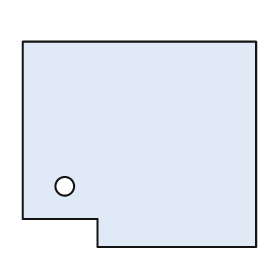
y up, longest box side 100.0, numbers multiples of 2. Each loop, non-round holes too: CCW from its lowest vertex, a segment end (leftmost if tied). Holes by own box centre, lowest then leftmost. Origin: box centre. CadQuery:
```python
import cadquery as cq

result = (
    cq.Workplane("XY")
    .moveTo(-18.0, -44.0)
    .lineTo(50.0, -44.0)
    .lineTo(50.0, 44.0)
    .lineTo(-50.0, 44.0)
    .lineTo(-50.0, -32.0)
    .lineTo(-18.0, -32.0)
    .close()
    .moveTo(-32.0, -18.0)
    .circle(4.0)
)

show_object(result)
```